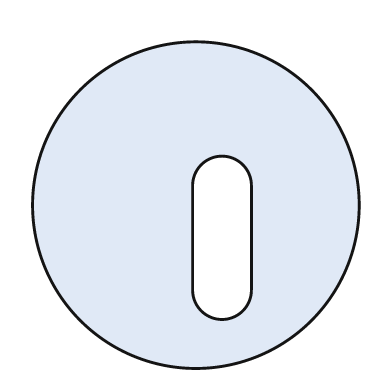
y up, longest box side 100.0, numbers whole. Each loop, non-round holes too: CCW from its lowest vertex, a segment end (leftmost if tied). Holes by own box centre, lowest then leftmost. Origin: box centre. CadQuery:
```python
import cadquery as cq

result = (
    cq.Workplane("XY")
    .moveTo(0.0, 0.0)
    .circle(50.0)
    .moveTo(-1.0, -26.0)
    .threePointArc((8.0, -35.0), (17.0, -26.0))
    .lineTo(17.0, 6.0)
    .threePointArc((8.0, 15.0), (-1.0, 6.0))
    .close()
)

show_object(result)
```